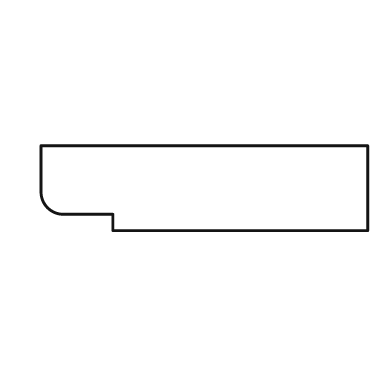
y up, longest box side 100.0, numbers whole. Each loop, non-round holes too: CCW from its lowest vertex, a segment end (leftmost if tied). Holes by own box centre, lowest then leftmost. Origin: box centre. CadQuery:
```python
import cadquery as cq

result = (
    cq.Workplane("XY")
    .moveTo(-28.0, -13.0)
    .lineTo(50.0, -13.0)
    .lineTo(50.0, 13.0)
    .lineTo(-50.0, 13.0)
    .lineTo(-50.0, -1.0)
    .threePointArc((-48.0, -6.0), (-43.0, -8.0))
    .lineTo(-28.0, -8.0)
    .close()
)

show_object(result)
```